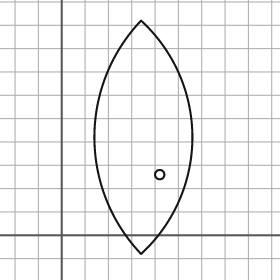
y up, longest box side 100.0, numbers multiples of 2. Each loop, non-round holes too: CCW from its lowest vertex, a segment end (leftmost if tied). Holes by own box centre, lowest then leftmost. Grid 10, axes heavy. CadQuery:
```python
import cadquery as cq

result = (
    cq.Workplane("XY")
    .moveTo(34.0, -8.0)
    .threePointArc((56.0, 42.0), (34.0, 92.0))
    .threePointArc((14.0, 42.0), (34.0, -8.0))
    .close()
    .moveTo(42.0, 26.0)
    .circle(2.0)
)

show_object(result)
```